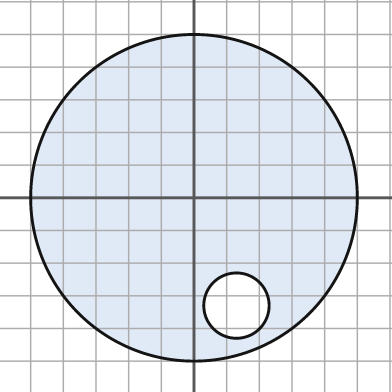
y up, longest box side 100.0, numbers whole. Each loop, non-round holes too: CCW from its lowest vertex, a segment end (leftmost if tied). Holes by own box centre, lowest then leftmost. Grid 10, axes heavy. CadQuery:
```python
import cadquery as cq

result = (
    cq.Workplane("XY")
    .moveTo(0.0, 0.0)
    .circle(50.0)
    .moveTo(13.0, -33.0)
    .circle(10.0)
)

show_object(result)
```